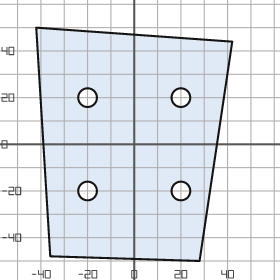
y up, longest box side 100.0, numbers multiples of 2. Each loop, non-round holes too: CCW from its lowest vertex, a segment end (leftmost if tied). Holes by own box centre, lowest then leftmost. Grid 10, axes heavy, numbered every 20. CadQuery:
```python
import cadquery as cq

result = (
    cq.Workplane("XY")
    .moveTo(28.0, -50.0)
    .lineTo(42.0, 44.0)
    .lineTo(-42.0, 50.0)
    .lineTo(-36.0, -48.0)
    .close()
    .moveTo(-20.0, -20.0)
    .circle(4.0)
    .moveTo(20.0, -20.0)
    .circle(4.0)
    .moveTo(-20.0, 20.0)
    .circle(4.0)
    .moveTo(20.0, 20.0)
    .circle(4.0)
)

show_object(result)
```